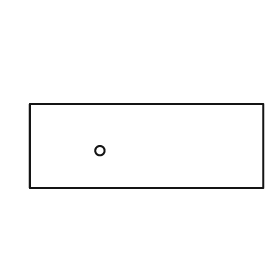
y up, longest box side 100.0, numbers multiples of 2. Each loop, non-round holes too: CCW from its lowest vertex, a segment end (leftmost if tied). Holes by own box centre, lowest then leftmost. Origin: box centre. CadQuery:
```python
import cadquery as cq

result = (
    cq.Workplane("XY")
    .moveTo(-50.0, -18.0)
    .lineTo(50.0, -18.0)
    .lineTo(50.0, 18.0)
    .lineTo(-50.0, 18.0)
    .close()
    .moveTo(-20.0, -2.0)
    .circle(2.0)
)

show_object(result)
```